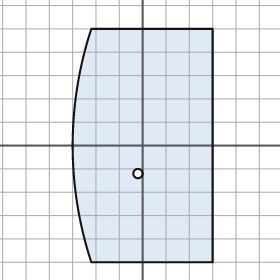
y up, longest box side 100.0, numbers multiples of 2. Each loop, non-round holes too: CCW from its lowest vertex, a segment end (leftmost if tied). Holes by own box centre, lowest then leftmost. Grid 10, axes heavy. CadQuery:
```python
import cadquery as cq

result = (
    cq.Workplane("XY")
    .moveTo(-22.0, -50.0)
    .lineTo(30.0, -50.0)
    .lineTo(30.0, 50.0)
    .lineTo(-22.0, 50.0)
    .threePointArc((-30.0, 0.0), (-22.0, -50.0))
    .close()
    .moveTo(-2.0, -12.0)
    .circle(2.0)
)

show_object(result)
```